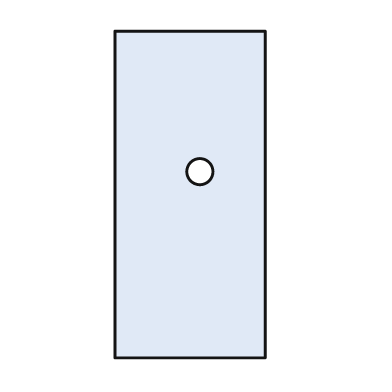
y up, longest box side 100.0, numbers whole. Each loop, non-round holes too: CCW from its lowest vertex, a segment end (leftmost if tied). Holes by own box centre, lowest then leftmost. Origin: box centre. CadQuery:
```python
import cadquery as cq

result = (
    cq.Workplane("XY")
    .moveTo(-23.0, -50.0)
    .lineTo(23.0, -50.0)
    .lineTo(23.0, 50.0)
    .lineTo(-23.0, 50.0)
    .close()
    .moveTo(3.0, 7.0)
    .circle(4.0)
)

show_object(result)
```